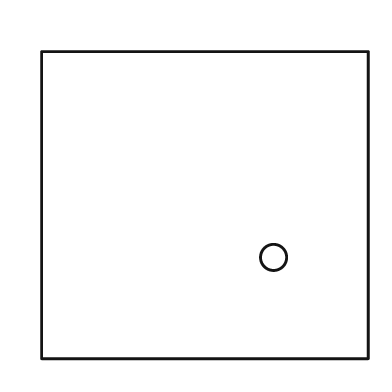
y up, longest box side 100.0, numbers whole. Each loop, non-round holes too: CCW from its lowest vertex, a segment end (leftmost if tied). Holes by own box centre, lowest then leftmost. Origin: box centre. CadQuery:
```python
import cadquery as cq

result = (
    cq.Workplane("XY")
    .moveTo(-50.0, -47.0)
    .lineTo(50.0, -47.0)
    .lineTo(50.0, 47.0)
    .lineTo(-50.0, 47.0)
    .close()
    .moveTo(21.0, -16.0)
    .circle(4.0)
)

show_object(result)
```